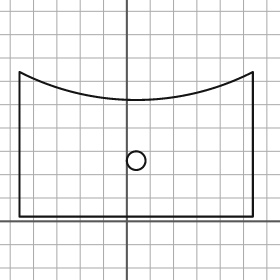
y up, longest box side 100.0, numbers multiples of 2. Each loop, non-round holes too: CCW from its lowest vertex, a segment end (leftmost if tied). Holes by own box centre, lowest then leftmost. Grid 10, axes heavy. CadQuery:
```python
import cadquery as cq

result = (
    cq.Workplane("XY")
    .moveTo(-46.0, 2.0)
    .lineTo(54.0, 2.0)
    .lineTo(54.0, 64.0)
    .threePointArc((4.0, 52.0), (-46.0, 64.0))
    .close()
    .moveTo(4.0, 26.0)
    .circle(4.0)
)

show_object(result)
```